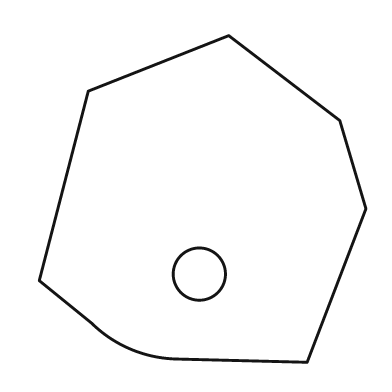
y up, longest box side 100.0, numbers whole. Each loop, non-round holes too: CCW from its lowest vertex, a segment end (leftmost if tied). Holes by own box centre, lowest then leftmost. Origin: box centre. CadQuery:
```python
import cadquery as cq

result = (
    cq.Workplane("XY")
    .moveTo(32.0, -50.0)
    .lineTo(50.0, -3.0)
    .lineTo(42.0, 24.0)
    .lineTo(8.0, 50.0)
    .lineTo(-35.0, 33.0)
    .lineTo(-50.0, -25.0)
    .lineTo(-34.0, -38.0)
    .threePointArc((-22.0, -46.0), (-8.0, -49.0))
    .close()
    .moveTo(-1.0, -23.0)
    .circle(8.0)
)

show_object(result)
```